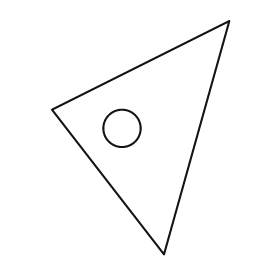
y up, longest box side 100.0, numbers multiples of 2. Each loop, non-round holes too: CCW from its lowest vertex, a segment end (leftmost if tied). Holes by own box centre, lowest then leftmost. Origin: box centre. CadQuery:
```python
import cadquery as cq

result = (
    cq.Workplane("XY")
    .moveTo(10.0, -50.0)
    .lineTo(38.0, 50.0)
    .lineTo(-38.0, 12.0)
    .close()
    .moveTo(-8.0, 4.0)
    .circle(8.0)
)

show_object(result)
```